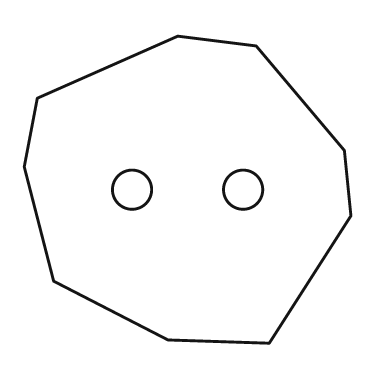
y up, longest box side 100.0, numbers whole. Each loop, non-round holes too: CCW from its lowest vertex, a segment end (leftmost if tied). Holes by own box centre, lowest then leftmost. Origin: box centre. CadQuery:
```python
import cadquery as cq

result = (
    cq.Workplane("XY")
    .moveTo(25.0, -47.0)
    .lineTo(50.0, -8.0)
    .lineTo(48.0, 12.0)
    .lineTo(21.0, 44.0)
    .lineTo(-3.0, 47.0)
    .lineTo(-46.0, 28.0)
    .lineTo(-50.0, 7.0)
    .lineTo(-41.0, -28.0)
    .lineTo(-6.0, -46.0)
    .close()
    .moveTo(-17.0, 0.0)
    .circle(6.0)
    .moveTo(17.0, 0.0)
    .circle(6.0)
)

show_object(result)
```